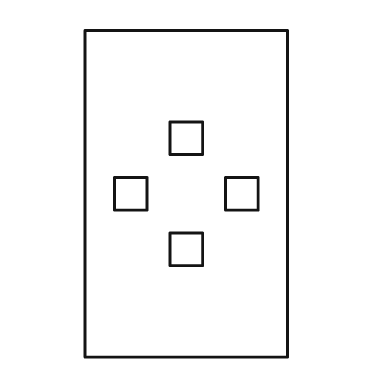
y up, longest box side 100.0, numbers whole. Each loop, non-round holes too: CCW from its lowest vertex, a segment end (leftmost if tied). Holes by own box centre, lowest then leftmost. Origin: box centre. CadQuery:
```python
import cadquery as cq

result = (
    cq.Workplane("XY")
    .moveTo(-31.0, -50.0)
    .lineTo(31.0, -50.0)
    .lineTo(31.0, 50.0)
    .lineTo(-31.0, 50.0)
    .close()
    .moveTo(-5.0, -22.0)
    .lineTo(5.0, -22.0)
    .lineTo(5.0, -12.0)
    .lineTo(-5.0, -12.0)
    .close()
    .moveTo(-22.0, -5.0)
    .lineTo(-12.0, -5.0)
    .lineTo(-12.0, 5.0)
    .lineTo(-22.0, 5.0)
    .close()
    .moveTo(12.0, -5.0)
    .lineTo(22.0, -5.0)
    .lineTo(22.0, 5.0)
    .lineTo(12.0, 5.0)
    .close()
    .moveTo(-5.0, 12.0)
    .lineTo(5.0, 12.0)
    .lineTo(5.0, 22.0)
    .lineTo(-5.0, 22.0)
    .close()
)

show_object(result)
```